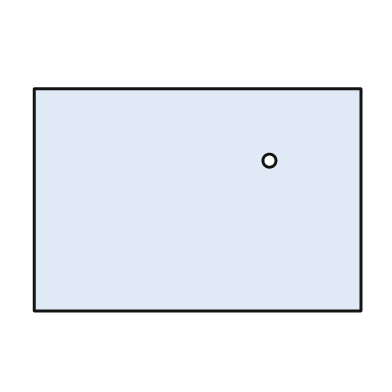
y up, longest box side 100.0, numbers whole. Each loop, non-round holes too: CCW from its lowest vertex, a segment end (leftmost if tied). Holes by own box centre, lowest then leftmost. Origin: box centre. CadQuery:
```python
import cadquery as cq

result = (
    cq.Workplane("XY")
    .moveTo(-50.0, -34.0)
    .lineTo(50.0, -34.0)
    .lineTo(50.0, 34.0)
    .lineTo(-50.0, 34.0)
    .close()
    .moveTo(22.0, 12.0)
    .circle(2.0)
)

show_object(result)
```